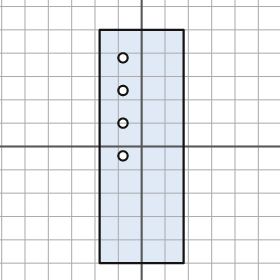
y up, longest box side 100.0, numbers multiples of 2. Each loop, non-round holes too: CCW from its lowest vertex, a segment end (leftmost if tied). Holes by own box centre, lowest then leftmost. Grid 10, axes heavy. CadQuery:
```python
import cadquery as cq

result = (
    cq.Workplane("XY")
    .moveTo(-18.0, -50.0)
    .lineTo(18.0, -50.0)
    .lineTo(18.0, 50.0)
    .lineTo(-18.0, 50.0)
    .close()
    .moveTo(-8.0, -4.0)
    .circle(2.0)
    .moveTo(-8.0, 10.0)
    .circle(2.0)
    .moveTo(-8.0, 24.0)
    .circle(2.0)
    .moveTo(-8.0, 38.0)
    .circle(2.0)
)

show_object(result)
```